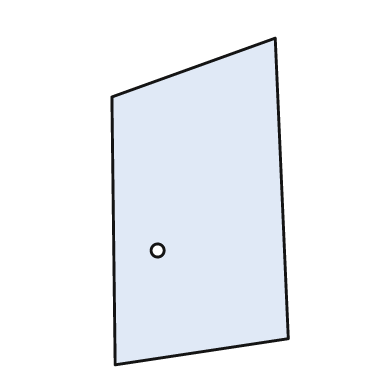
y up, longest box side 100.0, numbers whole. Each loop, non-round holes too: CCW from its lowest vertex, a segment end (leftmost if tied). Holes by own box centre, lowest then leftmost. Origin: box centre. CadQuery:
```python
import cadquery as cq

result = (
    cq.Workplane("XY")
    .moveTo(-26.0, -50.0)
    .lineTo(27.0, -42.0)
    .lineTo(23.0, 50.0)
    .lineTo(-27.0, 32.0)
    .close()
    .moveTo(-13.0, -15.0)
    .circle(2.0)
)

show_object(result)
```